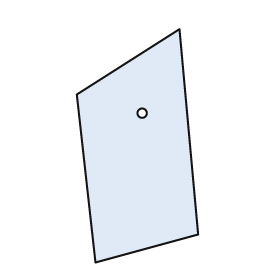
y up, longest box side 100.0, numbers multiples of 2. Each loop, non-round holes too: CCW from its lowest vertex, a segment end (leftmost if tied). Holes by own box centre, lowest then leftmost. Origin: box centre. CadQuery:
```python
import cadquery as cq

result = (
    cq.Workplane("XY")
    .moveTo(-18.0, -50.0)
    .lineTo(26.0, -38.0)
    .lineTo(18.0, 50.0)
    .lineTo(-26.0, 22.0)
    .close()
    .moveTo(2.0, 14.0)
    .circle(2.0)
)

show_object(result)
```